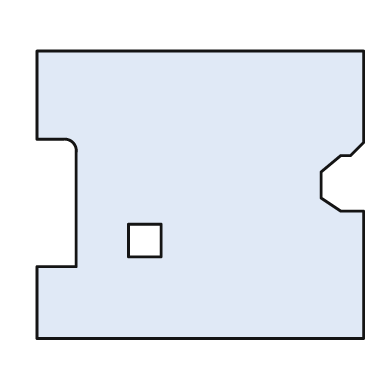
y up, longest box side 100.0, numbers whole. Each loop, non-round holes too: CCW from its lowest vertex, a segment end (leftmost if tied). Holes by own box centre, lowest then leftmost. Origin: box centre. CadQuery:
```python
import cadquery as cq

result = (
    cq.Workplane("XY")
    .moveTo(-50.0, -44.0)
    .lineTo(50.0, -44.0)
    .lineTo(50.0, -5.0)
    .lineTo(43.0, -5.0)
    .lineTo(37.0, -1.0)
    .lineTo(37.0, 7.0)
    .lineTo(43.0, 12.0)
    .lineTo(46.0, 12.0)
    .lineTo(50.0, 16.0)
    .lineTo(50.0, 44.0)
    .lineTo(-50.0, 44.0)
    .lineTo(-50.0, 17.0)
    .lineTo(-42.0, 17.0)
    .threePointArc((-39.0, 16.0), (-38.0, 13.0))
    .lineTo(-38.0, -22.0)
    .lineTo(-50.0, -22.0)
    .close()
    .moveTo(-22.0, -19.0)
    .lineTo(-12.0, -19.0)
    .lineTo(-12.0, -9.0)
    .lineTo(-22.0, -9.0)
    .close()
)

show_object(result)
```